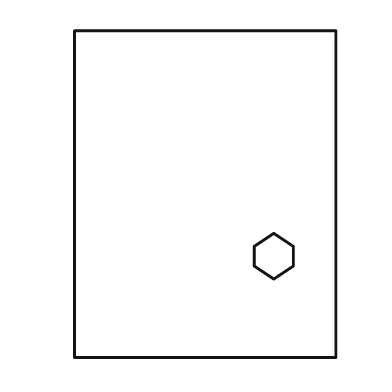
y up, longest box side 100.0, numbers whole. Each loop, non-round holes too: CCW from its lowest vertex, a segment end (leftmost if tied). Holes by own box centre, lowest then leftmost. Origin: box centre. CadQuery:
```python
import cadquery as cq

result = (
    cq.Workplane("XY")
    .moveTo(-40.0, -50.0)
    .lineTo(40.0, -50.0)
    .lineTo(40.0, 50.0)
    .lineTo(-40.0, 50.0)
    .close()
    .moveTo(21.0, -26.0)
    .lineTo(27.0, -22.0)
    .lineTo(27.0, -16.0)
    .lineTo(21.0, -12.0)
    .lineTo(15.0, -16.0)
    .lineTo(15.0, -22.0)
    .close()
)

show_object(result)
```